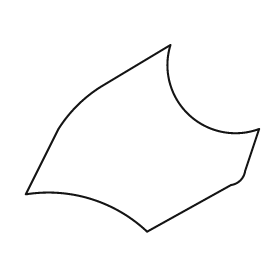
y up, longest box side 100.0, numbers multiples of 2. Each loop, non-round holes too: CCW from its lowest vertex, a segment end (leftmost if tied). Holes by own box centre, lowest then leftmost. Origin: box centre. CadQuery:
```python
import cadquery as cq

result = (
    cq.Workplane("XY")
    .moveTo(2.0, -40.0)
    .lineTo(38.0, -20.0)
    .threePointArc((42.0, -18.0), (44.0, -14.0))
    .lineTo(50.0, 4.0)
    .threePointArc((20.0, 10.0), (12.0, 40.0))
    .lineTo(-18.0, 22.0)
    .threePointArc((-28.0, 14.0), (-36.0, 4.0))
    .lineTo(-50.0, -24.0)
    .threePointArc((-22.0, -26.0), (2.0, -40.0))
    .close()
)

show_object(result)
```